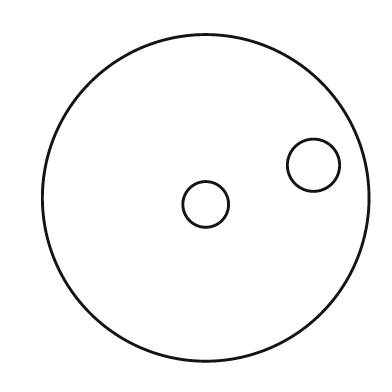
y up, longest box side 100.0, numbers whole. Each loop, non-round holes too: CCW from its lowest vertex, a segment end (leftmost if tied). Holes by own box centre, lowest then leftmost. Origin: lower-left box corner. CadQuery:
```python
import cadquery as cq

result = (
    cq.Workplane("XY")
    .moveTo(50.0, 50.0)
    .circle(50.0)
    .moveTo(50.0, 48.0)
    .circle(7.0)
    .moveTo(83.0, 60.0)
    .circle(8.0)
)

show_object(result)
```